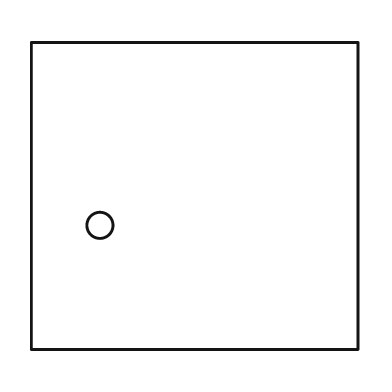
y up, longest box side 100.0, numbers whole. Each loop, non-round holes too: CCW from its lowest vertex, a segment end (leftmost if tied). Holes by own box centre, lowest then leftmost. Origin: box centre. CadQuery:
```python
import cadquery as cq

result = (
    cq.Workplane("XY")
    .moveTo(-50.0, -47.0)
    .lineTo(50.0, -47.0)
    .lineTo(50.0, 47.0)
    .lineTo(-50.0, 47.0)
    .close()
    .moveTo(-29.0, -9.0)
    .circle(4.0)
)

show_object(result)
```